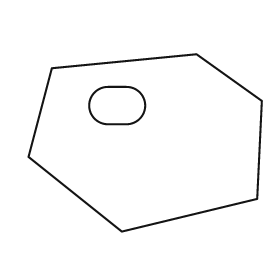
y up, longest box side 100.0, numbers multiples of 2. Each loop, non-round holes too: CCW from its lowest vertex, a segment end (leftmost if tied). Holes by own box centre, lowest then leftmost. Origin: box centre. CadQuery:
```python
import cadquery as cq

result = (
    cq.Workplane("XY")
    .moveTo(-10.0, -38.0)
    .lineTo(48.0, -24.0)
    .lineTo(50.0, 18.0)
    .lineTo(22.0, 38.0)
    .lineTo(-40.0, 32.0)
    .lineTo(-50.0, -6.0)
    .close()
    .moveTo(-16.0, 8.0)
    .lineTo(-8.0, 8.0)
    .threePointArc((0.0, 16.0), (-8.0, 24.0))
    .lineTo(-16.0, 24.0)
    .threePointArc((-24.0, 16.0), (-16.0, 8.0))
    .close()
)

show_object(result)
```